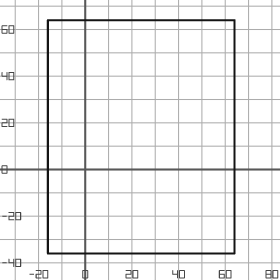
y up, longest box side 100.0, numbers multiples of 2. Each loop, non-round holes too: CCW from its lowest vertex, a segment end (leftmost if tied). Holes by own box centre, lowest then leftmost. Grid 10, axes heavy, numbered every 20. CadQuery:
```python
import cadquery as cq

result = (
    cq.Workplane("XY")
    .moveTo(-16.0, -36.0)
    .lineTo(64.0, -36.0)
    .lineTo(64.0, 64.0)
    .lineTo(-16.0, 64.0)
    .close()
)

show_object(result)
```